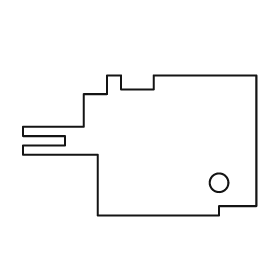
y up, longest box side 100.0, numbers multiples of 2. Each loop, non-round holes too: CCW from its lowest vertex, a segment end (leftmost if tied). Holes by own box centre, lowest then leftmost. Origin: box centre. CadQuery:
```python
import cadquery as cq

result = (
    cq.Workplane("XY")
    .moveTo(-18.0, -30.0)
    .lineTo(34.0, -30.0)
    .lineTo(34.0, -26.0)
    .lineTo(50.0, -26.0)
    .lineTo(50.0, 30.0)
    .lineTo(6.0, 30.0)
    .lineTo(6.0, 24.0)
    .lineTo(-8.0, 24.0)
    .lineTo(-8.0, 30.0)
    .lineTo(-14.0, 30.0)
    .lineTo(-14.0, 22.0)
    .lineTo(-24.0, 22.0)
    .lineTo(-24.0, 8.0)
    .lineTo(-50.0, 8.0)
    .lineTo(-50.0, 4.0)
    .lineTo(-32.0, 4.0)
    .lineTo(-32.0, 0.0)
    .lineTo(-50.0, 0.0)
    .lineTo(-50.0, -4.0)
    .lineTo(-18.0, -4.0)
    .close()
    .moveTo(34.0, -16.0)
    .circle(4.0)
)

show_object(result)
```